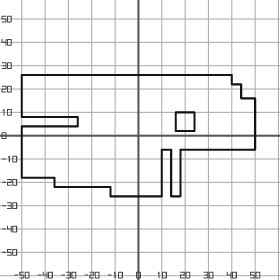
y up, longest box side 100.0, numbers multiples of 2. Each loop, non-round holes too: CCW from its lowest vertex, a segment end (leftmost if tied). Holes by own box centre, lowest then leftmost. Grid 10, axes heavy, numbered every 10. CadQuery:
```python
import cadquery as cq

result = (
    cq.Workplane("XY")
    .moveTo(-12.0, -26.0)
    .lineTo(10.0, -26.0)
    .lineTo(10.0, -6.0)
    .lineTo(14.0, -6.0)
    .lineTo(14.0, -26.0)
    .lineTo(18.0, -26.0)
    .lineTo(18.0, -6.0)
    .lineTo(50.0, -6.0)
    .lineTo(50.0, 16.0)
    .lineTo(44.0, 16.0)
    .lineTo(44.0, 22.0)
    .lineTo(40.0, 22.0)
    .lineTo(40.0, 26.0)
    .lineTo(-50.0, 26.0)
    .lineTo(-50.0, 8.0)
    .lineTo(-26.0, 8.0)
    .lineTo(-26.0, 4.0)
    .lineTo(-50.0, 4.0)
    .lineTo(-50.0, -18.0)
    .lineTo(-36.0, -18.0)
    .lineTo(-36.0, -22.0)
    .lineTo(-12.0, -22.0)
    .close()
    .moveTo(16.0, 2.0)
    .lineTo(24.0, 2.0)
    .lineTo(24.0, 10.0)
    .lineTo(16.0, 10.0)
    .close()
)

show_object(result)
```